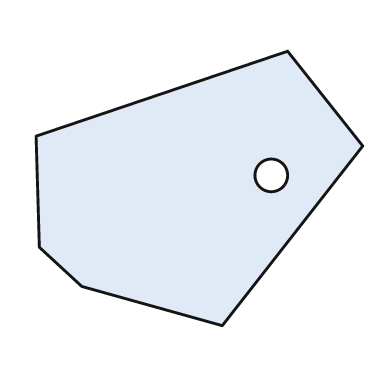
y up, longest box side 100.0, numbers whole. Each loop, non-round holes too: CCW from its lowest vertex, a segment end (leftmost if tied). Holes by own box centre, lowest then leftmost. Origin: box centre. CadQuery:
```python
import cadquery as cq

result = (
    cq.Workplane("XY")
    .moveTo(7.0, -42.0)
    .lineTo(50.0, 13.0)
    .lineTo(27.0, 42.0)
    .lineTo(-50.0, 16.0)
    .lineTo(-49.0, -18.0)
    .lineTo(-36.0, -30.0)
    .close()
    .moveTo(22.0, 4.0)
    .circle(5.0)
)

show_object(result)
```